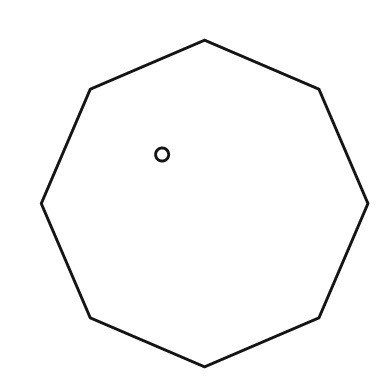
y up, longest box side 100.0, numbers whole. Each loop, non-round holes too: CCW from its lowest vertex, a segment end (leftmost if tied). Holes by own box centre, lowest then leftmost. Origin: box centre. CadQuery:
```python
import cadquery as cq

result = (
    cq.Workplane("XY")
    .moveTo(0.0, -50.0)
    .lineTo(35.0, -35.0)
    .lineTo(50.0, 0.0)
    .lineTo(35.0, 35.0)
    .lineTo(0.0, 50.0)
    .lineTo(-35.0, 35.0)
    .lineTo(-50.0, 0.0)
    .lineTo(-35.0, -35.0)
    .close()
    .moveTo(-13.0, 15.0)
    .circle(2.0)
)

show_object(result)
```